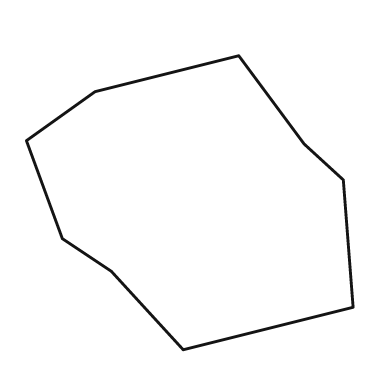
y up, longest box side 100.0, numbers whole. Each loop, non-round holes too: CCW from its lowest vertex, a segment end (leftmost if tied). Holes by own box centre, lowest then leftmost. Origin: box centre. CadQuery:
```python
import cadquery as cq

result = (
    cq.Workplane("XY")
    .moveTo(-2.0, -45.0)
    .lineTo(50.0, -32.0)
    .lineTo(47.0, 7.0)
    .lineTo(35.0, 18.0)
    .lineTo(15.0, 45.0)
    .lineTo(-29.0, 34.0)
    .lineTo(-50.0, 19.0)
    .lineTo(-39.0, -11.0)
    .lineTo(-24.0, -21.0)
    .close()
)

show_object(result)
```